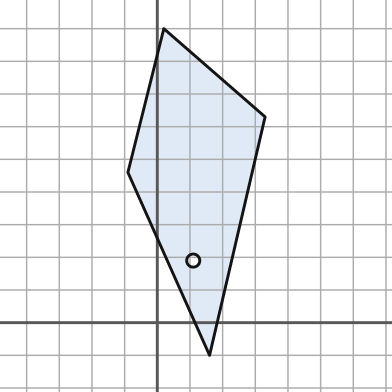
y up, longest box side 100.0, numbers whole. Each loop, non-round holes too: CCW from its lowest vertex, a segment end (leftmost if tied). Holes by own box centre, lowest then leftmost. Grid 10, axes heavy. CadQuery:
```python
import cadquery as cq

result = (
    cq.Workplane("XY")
    .moveTo(16.0, -10.0)
    .lineTo(33.0, 63.0)
    .lineTo(2.0, 90.0)
    .lineTo(-9.0, 46.0)
    .close()
    .moveTo(11.0, 19.0)
    .circle(2.0)
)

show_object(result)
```